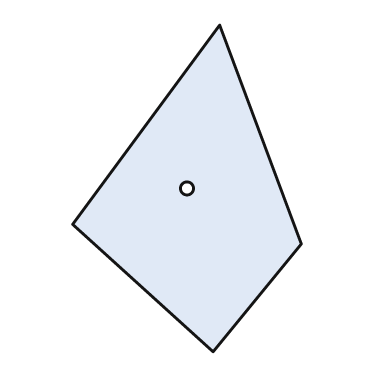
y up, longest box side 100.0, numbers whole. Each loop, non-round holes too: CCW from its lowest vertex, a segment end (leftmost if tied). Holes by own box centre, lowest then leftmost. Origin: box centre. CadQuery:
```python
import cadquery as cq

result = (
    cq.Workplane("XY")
    .moveTo(8.0, -50.0)
    .lineTo(35.0, -17.0)
    .lineTo(10.0, 50.0)
    .lineTo(-35.0, -11.0)
    .close()
    .moveTo(0.0, 0.0)
    .circle(2.0)
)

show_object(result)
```